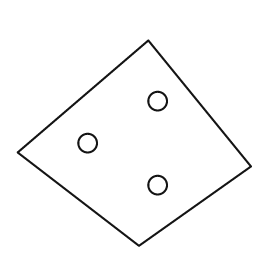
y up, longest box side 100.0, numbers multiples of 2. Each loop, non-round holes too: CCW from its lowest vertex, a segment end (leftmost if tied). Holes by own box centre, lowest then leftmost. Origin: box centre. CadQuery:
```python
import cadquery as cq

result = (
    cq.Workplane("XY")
    .moveTo(2.0, -44.0)
    .lineTo(50.0, -10.0)
    .lineTo(6.0, 44.0)
    .lineTo(-50.0, -4.0)
    .close()
    .moveTo(10.0, -18.0)
    .circle(4.0)
    .moveTo(-20.0, 0.0)
    .circle(4.0)
    .moveTo(10.0, 18.0)
    .circle(4.0)
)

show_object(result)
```